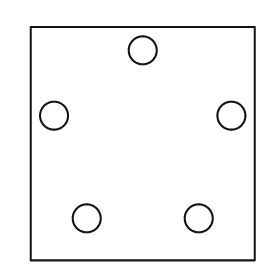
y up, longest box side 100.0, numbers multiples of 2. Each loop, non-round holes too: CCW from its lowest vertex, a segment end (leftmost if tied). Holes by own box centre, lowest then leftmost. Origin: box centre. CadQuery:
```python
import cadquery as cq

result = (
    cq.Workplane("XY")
    .moveTo(-48.0, -50.0)
    .lineTo(48.0, -50.0)
    .lineTo(48.0, 50.0)
    .lineTo(-48.0, 50.0)
    .close()
    .moveTo(-24.0, -32.0)
    .circle(6.0)
    .moveTo(24.0, -32.0)
    .circle(6.0)
    .moveTo(-38.0, 12.0)
    .circle(6.0)
    .moveTo(38.0, 12.0)
    .circle(6.0)
    .moveTo(0.0, 40.0)
    .circle(6.0)
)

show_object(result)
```